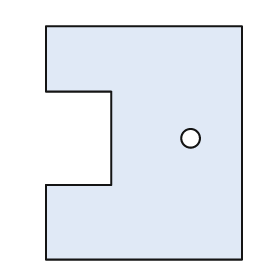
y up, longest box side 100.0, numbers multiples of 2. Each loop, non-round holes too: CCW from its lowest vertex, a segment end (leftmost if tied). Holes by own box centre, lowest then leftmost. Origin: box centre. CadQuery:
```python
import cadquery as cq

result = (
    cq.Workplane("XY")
    .moveTo(-42.0, -50.0)
    .lineTo(42.0, -50.0)
    .lineTo(42.0, 50.0)
    .lineTo(-42.0, 50.0)
    .lineTo(-42.0, 22.0)
    .lineTo(-14.0, 22.0)
    .lineTo(-14.0, -18.0)
    .lineTo(-42.0, -18.0)
    .close()
    .moveTo(20.0, 2.0)
    .circle(4.0)
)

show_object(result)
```